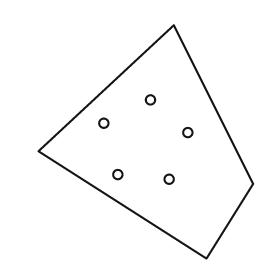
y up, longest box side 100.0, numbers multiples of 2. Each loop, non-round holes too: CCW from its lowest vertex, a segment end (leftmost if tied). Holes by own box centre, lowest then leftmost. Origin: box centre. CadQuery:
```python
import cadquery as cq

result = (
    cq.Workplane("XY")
    .moveTo(26.0, -50.0)
    .lineTo(46.0, -18.0)
    .lineTo(12.0, 50.0)
    .lineTo(-46.0, -4.0)
    .close()
    .moveTo(10.0, -16.0)
    .circle(2.0)
    .moveTo(-12.0, -14.0)
    .circle(2.0)
    .moveTo(18.0, 4.0)
    .circle(2.0)
    .moveTo(-18.0, 8.0)
    .circle(2.0)
    .moveTo(2.0, 18.0)
    .circle(2.0)
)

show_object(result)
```